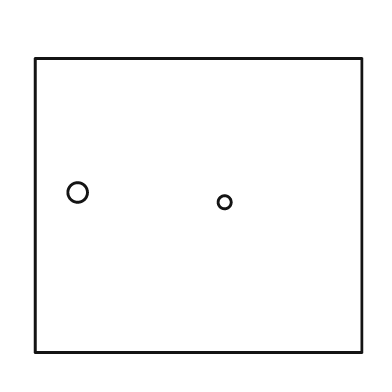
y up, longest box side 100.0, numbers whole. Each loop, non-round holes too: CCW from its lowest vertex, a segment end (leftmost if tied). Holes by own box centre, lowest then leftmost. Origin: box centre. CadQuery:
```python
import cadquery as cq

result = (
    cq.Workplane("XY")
    .moveTo(-50.0, -45.0)
    .lineTo(50.0, -45.0)
    .lineTo(50.0, 45.0)
    .lineTo(-50.0, 45.0)
    .close()
    .moveTo(8.0, 1.0)
    .circle(2.0)
    .moveTo(-37.0, 4.0)
    .circle(3.0)
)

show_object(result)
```